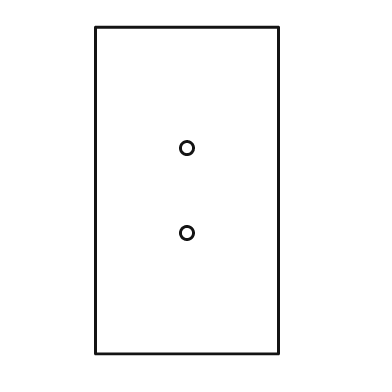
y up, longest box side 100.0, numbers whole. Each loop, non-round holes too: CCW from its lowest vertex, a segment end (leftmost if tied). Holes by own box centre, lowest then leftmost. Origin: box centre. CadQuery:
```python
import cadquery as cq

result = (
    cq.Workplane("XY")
    .moveTo(-28.0, -50.0)
    .lineTo(28.0, -50.0)
    .lineTo(28.0, 50.0)
    .lineTo(-28.0, 50.0)
    .close()
    .moveTo(0.0, -13.0)
    .circle(2.0)
    .moveTo(0.0, 13.0)
    .circle(2.0)
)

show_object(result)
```